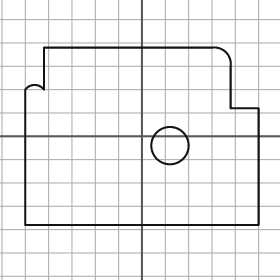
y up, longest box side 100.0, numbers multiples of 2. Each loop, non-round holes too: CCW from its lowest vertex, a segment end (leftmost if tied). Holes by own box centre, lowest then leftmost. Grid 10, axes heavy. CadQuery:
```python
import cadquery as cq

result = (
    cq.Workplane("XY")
    .moveTo(-50.0, -38.0)
    .lineTo(50.0, -38.0)
    .lineTo(50.0, 12.0)
    .lineTo(38.0, 12.0)
    .lineTo(38.0, 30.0)
    .threePointArc((36.0, 36.0), (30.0, 38.0))
    .lineTo(-42.0, 38.0)
    .lineTo(-42.0, 20.0)
    .threePointArc((-46.0, 22.0), (-50.0, 20.0))
    .close()
    .moveTo(12.0, -4.0)
    .circle(8.0)
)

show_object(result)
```